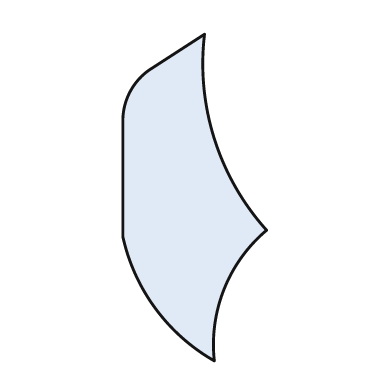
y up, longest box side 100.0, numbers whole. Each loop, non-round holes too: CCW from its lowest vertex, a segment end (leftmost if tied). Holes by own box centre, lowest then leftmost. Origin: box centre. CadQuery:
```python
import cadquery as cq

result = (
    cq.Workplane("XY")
    .moveTo(6.0, -50.0)
    .threePointArc((9.0, -28.0), (22.0, -10.0))
    .threePointArc((6.0, 18.0), (3.0, 50.0))
    .lineTo(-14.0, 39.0)
    .threePointArc((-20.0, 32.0), (-22.0, 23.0))
    .lineTo(-22.0, -12.0)
    .threePointArc((-12.0, -34.0), (6.0, -50.0))
    .close()
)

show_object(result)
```